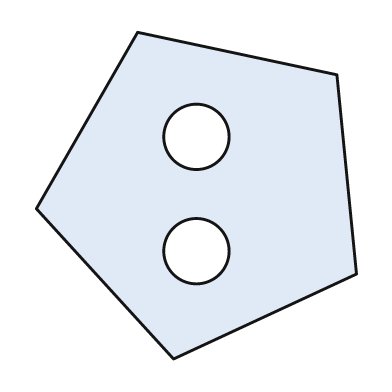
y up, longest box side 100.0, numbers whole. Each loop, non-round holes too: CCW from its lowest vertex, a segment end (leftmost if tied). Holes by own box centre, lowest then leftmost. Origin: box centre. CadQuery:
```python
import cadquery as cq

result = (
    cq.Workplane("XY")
    .moveTo(-7.0, -50.0)
    .lineTo(49.0, -24.0)
    .lineTo(43.0, 37.0)
    .lineTo(-18.0, 50.0)
    .lineTo(-49.0, -4.0)
    .close()
    .moveTo(0.0, -17.0)
    .circle(10.0)
    .moveTo(0.0, 18.0)
    .circle(10.0)
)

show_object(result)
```